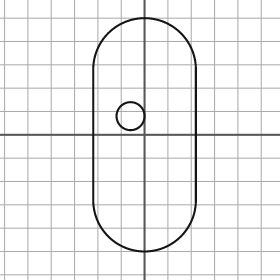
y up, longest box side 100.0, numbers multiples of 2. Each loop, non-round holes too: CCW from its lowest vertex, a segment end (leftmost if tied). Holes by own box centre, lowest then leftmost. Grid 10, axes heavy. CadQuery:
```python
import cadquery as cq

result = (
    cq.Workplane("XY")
    .moveTo(-22.0, -28.0)
    .threePointArc((0.0, -50.0), (22.0, -28.0))
    .lineTo(22.0, 28.0)
    .threePointArc((0.0, 50.0), (-22.0, 28.0))
    .close()
    .moveTo(-6.0, 8.0)
    .circle(6.0)
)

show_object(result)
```